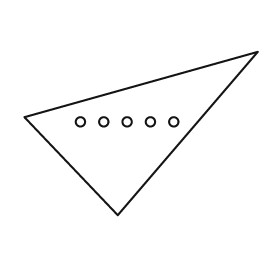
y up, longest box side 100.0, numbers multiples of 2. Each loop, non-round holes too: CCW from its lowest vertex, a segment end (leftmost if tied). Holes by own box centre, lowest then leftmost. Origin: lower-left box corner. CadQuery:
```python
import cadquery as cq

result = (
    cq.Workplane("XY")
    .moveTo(40.0, 0.0)
    .lineTo(100.0, 70.0)
    .lineTo(0.0, 42.0)
    .close()
    .moveTo(24.0, 40.0)
    .circle(2.0)
    .moveTo(34.0, 40.0)
    .circle(2.0)
    .moveTo(44.0, 40.0)
    .circle(2.0)
    .moveTo(54.0, 40.0)
    .circle(2.0)
    .moveTo(64.0, 40.0)
    .circle(2.0)
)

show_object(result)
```